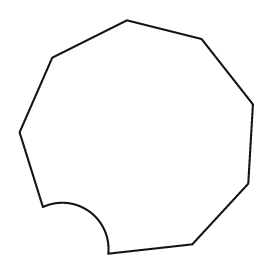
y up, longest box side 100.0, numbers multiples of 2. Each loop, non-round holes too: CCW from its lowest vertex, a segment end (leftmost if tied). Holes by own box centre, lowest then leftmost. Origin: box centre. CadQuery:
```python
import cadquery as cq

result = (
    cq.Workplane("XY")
    .moveTo(-12.0, -50.0)
    .lineTo(24.0, -46.0)
    .lineTo(48.0, -20.0)
    .lineTo(50.0, 14.0)
    .lineTo(28.0, 42.0)
    .lineTo(-4.0, 50.0)
    .lineTo(-36.0, 34.0)
    .lineTo(-50.0, 2.0)
    .lineTo(-40.0, -30.0)
    .threePointArc((-20.0, -32.0), (-12.0, -50.0))
    .close()
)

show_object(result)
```